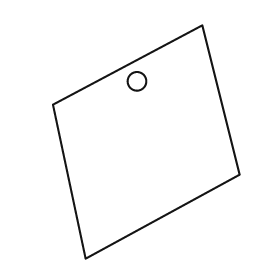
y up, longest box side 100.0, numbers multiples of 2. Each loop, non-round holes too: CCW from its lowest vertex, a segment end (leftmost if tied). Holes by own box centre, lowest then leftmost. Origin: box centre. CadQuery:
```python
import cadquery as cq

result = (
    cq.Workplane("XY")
    .moveTo(-26.0, -50.0)
    .lineTo(40.0, -14.0)
    .lineTo(24.0, 50.0)
    .lineTo(-40.0, 16.0)
    .close()
    .moveTo(-4.0, 26.0)
    .circle(4.0)
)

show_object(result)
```